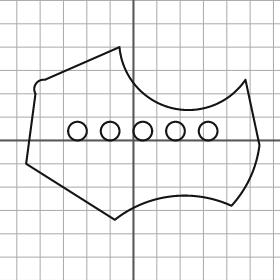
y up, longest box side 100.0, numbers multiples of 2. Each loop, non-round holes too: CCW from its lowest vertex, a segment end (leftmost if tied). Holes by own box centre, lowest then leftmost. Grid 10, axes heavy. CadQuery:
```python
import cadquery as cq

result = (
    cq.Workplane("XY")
    .moveTo(-8.0, -34.0)
    .threePointArc((16.0, -24.0), (42.0, -28.0))
    .threePointArc((50.0, -16.0), (54.0, -2.0))
    .lineTo(48.0, 26.0)
    .threePointArc((16.0, 14.0), (-6.0, 40.0))
    .lineTo(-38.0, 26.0)
    .threePointArc((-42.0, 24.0), (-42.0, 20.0))
    .lineTo(-46.0, -10.0)
    .close()
    .moveTo(-24.0, 4.0)
    .circle(4.0)
    .moveTo(-10.0, 4.0)
    .circle(4.0)
    .moveTo(4.0, 4.0)
    .circle(4.0)
    .moveTo(18.0, 4.0)
    .circle(4.0)
    .moveTo(32.0, 4.0)
    .circle(4.0)
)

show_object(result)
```